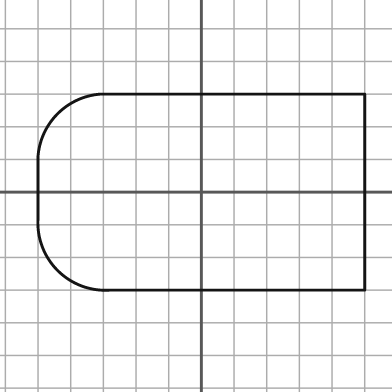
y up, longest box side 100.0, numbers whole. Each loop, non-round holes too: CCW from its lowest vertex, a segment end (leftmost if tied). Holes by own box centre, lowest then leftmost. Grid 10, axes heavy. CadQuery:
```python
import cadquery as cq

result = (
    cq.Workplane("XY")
    .moveTo(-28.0, -30.0)
    .lineTo(50.0, -30.0)
    .lineTo(50.0, 30.0)
    .lineTo(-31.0, 30.0)
    .threePointArc((-44.0, 24.0), (-50.0, 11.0))
    .lineTo(-50.0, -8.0)
    .threePointArc((-44.0, -24.0), (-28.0, -30.0))
    .close()
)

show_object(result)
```